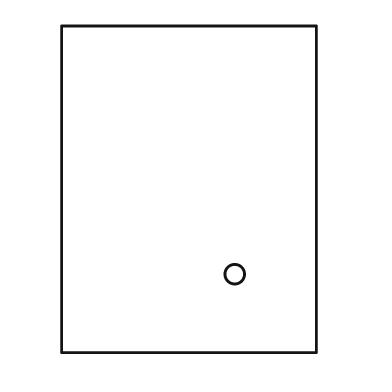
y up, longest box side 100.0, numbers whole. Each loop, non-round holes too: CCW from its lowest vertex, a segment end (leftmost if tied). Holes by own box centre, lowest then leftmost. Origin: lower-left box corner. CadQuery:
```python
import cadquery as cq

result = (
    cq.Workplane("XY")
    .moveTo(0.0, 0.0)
    .lineTo(78.0, 0.0)
    .lineTo(78.0, 100.0)
    .lineTo(0.0, 100.0)
    .close()
    .moveTo(53.0, 24.0)
    .circle(3.0)
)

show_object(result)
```